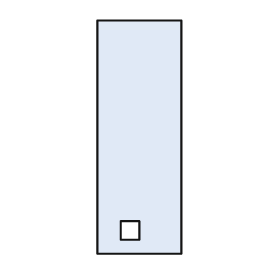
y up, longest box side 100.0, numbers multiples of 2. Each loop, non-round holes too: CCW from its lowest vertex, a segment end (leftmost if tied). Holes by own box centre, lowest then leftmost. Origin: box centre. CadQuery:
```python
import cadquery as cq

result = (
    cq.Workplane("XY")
    .moveTo(-18.0, -50.0)
    .lineTo(18.0, -50.0)
    .lineTo(18.0, 50.0)
    .lineTo(-18.0, 50.0)
    .close()
    .moveTo(-8.0, -44.0)
    .lineTo(0.0, -44.0)
    .lineTo(0.0, -36.0)
    .lineTo(-8.0, -36.0)
    .close()
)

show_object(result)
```